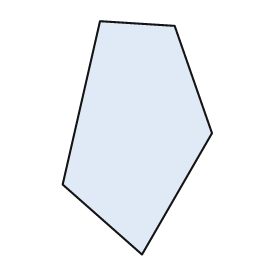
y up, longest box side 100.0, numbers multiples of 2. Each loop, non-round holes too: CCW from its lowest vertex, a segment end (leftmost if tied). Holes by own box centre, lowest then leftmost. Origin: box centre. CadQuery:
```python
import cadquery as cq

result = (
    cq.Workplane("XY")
    .moveTo(2.0, -50.0)
    .lineTo(32.0, 2.0)
    .lineTo(16.0, 48.0)
    .lineTo(-16.0, 50.0)
    .lineTo(-32.0, -20.0)
    .close()
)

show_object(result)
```